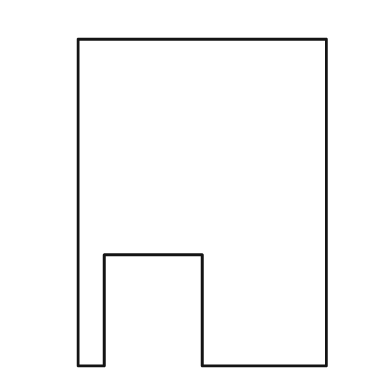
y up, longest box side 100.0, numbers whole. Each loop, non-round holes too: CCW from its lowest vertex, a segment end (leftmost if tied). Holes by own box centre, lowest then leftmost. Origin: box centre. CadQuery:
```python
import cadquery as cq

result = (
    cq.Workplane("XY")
    .moveTo(-38.0, -50.0)
    .lineTo(-30.0, -50.0)
    .lineTo(-30.0, -16.0)
    .lineTo(0.0, -16.0)
    .lineTo(0.0, -50.0)
    .lineTo(38.0, -50.0)
    .lineTo(38.0, 50.0)
    .lineTo(-38.0, 50.0)
    .close()
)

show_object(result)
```